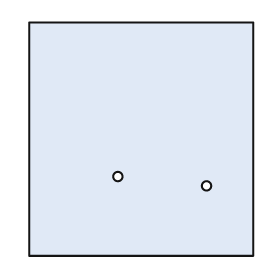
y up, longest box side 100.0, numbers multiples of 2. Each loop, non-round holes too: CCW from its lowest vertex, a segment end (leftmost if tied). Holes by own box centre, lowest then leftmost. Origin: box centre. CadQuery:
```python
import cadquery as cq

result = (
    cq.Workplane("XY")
    .moveTo(-48.0, -50.0)
    .lineTo(48.0, -50.0)
    .lineTo(48.0, 50.0)
    .lineTo(-48.0, 50.0)
    .close()
    .moveTo(28.0, -20.0)
    .circle(2.0)
    .moveTo(-10.0, -16.0)
    .circle(2.0)
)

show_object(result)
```